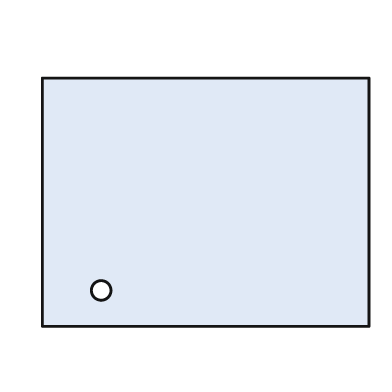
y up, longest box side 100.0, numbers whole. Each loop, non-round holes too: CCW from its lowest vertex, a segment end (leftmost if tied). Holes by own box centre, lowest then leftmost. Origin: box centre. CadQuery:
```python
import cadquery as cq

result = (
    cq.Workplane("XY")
    .moveTo(-50.0, -38.0)
    .lineTo(50.0, -38.0)
    .lineTo(50.0, 38.0)
    .lineTo(-50.0, 38.0)
    .close()
    .moveTo(-32.0, -27.0)
    .circle(3.0)
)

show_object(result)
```